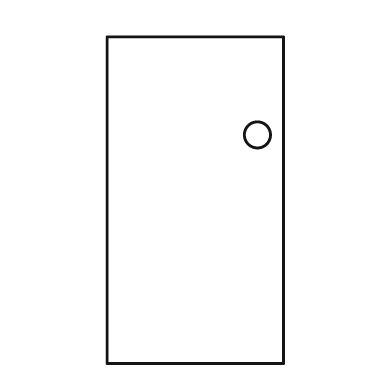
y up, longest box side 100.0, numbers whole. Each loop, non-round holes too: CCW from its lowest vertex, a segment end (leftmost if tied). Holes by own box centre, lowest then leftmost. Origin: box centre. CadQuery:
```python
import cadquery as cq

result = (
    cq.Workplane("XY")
    .moveTo(-27.0, -50.0)
    .lineTo(27.0, -50.0)
    .lineTo(27.0, 50.0)
    .lineTo(-27.0, 50.0)
    .close()
    .moveTo(19.0, 20.0)
    .circle(4.0)
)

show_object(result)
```